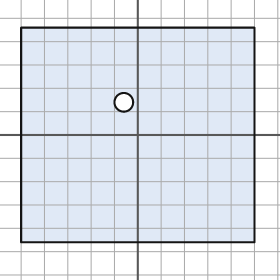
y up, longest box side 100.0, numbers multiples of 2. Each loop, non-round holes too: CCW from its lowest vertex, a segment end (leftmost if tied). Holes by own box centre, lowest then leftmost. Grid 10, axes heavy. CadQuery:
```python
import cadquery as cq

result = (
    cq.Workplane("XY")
    .moveTo(-50.0, -46.0)
    .lineTo(50.0, -46.0)
    .lineTo(50.0, 46.0)
    .lineTo(-50.0, 46.0)
    .close()
    .moveTo(-6.0, 14.0)
    .circle(4.0)
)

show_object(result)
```